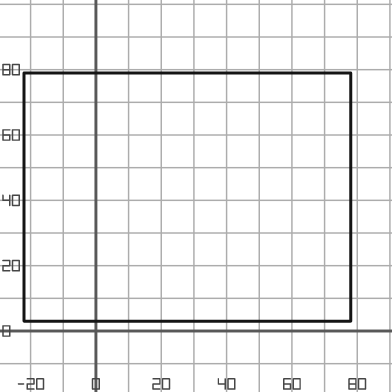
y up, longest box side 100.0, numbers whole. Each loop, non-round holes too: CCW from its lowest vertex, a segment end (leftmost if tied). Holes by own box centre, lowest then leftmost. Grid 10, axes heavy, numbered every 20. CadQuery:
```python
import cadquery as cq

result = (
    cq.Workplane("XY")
    .moveTo(-22.0, 3.0)
    .lineTo(78.0, 3.0)
    .lineTo(78.0, 79.0)
    .lineTo(-22.0, 79.0)
    .close()
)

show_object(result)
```